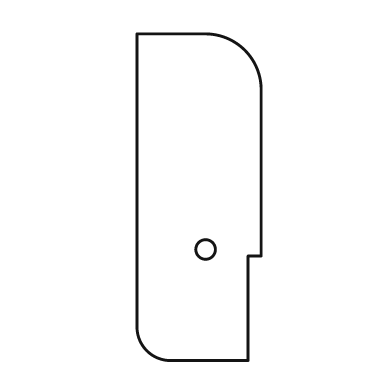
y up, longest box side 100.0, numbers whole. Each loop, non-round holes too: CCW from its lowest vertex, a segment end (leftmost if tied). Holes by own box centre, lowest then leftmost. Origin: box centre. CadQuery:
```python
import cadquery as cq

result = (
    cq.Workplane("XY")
    .moveTo(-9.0, -50.0)
    .lineTo(15.0, -50.0)
    .lineTo(15.0, -18.0)
    .lineTo(19.0, -18.0)
    .lineTo(19.0, 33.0)
    .threePointArc((14.0, 45.0), (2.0, 50.0))
    .lineTo(-19.0, 50.0)
    .lineTo(-19.0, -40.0)
    .threePointArc((-16.0, -47.0), (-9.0, -50.0))
    .close()
    .moveTo(2.0, -16.0)
    .circle(3.0)
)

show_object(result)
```